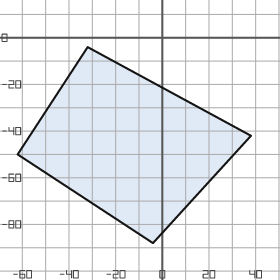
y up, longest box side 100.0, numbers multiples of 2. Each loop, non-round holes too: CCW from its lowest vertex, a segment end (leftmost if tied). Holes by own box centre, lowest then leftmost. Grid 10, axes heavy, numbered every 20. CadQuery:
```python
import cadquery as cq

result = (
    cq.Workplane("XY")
    .moveTo(-4.0, -88.0)
    .lineTo(38.0, -42.0)
    .lineTo(-32.0, -4.0)
    .lineTo(-62.0, -50.0)
    .close()
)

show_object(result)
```